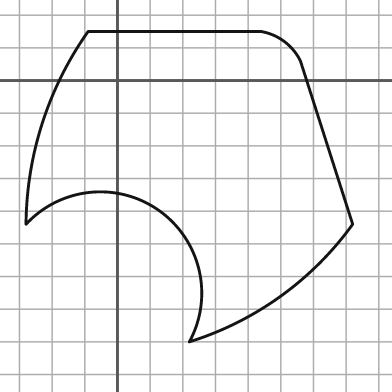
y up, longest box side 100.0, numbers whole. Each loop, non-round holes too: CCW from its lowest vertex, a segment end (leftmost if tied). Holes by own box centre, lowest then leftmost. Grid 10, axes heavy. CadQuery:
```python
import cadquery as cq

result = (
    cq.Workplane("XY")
    .moveTo(22.0, -80.0)
    .threePointArc((50.0, -66.0), (72.0, -44.0))
    .lineTo(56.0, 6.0)
    .threePointArc((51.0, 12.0), (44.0, 15.0))
    .lineTo(-9.0, 15.0)
    .threePointArc((-23.0, -13.0), (-28.0, -44.0))
    .threePointArc((13.0, -40.0), (22.0, -80.0))
    .close()
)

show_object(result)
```